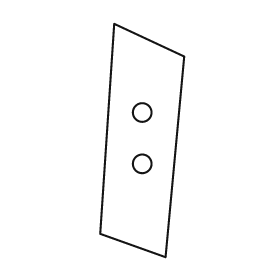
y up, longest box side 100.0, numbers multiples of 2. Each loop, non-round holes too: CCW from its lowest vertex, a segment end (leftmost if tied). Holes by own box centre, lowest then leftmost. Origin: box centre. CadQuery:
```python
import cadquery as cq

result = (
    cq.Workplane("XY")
    .moveTo(10.0, -50.0)
    .lineTo(18.0, 36.0)
    .lineTo(-12.0, 50.0)
    .lineTo(-18.0, -40.0)
    .close()
    .moveTo(0.0, -10.0)
    .circle(4.0)
    .moveTo(0.0, 12.0)
    .circle(4.0)
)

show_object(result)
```